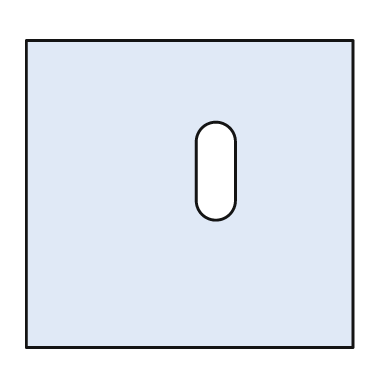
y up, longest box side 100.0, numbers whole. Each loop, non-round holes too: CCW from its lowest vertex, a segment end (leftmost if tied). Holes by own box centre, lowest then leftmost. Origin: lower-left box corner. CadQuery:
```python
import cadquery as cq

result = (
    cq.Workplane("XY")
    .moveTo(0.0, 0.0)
    .lineTo(100.0, 0.0)
    .lineTo(100.0, 94.0)
    .lineTo(0.0, 94.0)
    .close()
    .moveTo(52.0, 45.0)
    .threePointArc((58.0, 39.0), (64.0, 45.0))
    .lineTo(64.0, 63.0)
    .threePointArc((58.0, 69.0), (52.0, 63.0))
    .close()
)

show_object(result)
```